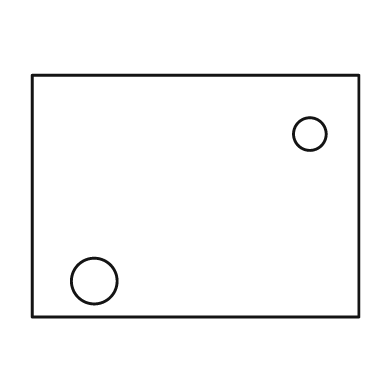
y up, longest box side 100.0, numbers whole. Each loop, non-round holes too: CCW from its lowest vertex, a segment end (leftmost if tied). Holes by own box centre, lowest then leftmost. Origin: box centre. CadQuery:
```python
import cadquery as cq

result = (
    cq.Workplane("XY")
    .moveTo(-50.0, -37.0)
    .lineTo(50.0, -37.0)
    .lineTo(50.0, 37.0)
    .lineTo(-50.0, 37.0)
    .close()
    .moveTo(-31.0, -26.0)
    .circle(7.0)
    .moveTo(35.0, 19.0)
    .circle(5.0)
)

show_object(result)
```